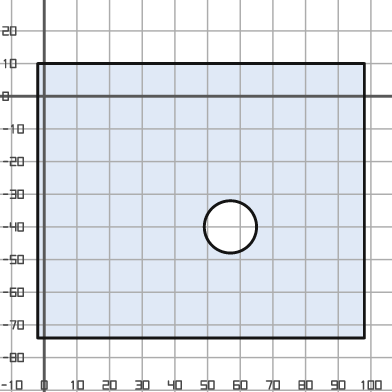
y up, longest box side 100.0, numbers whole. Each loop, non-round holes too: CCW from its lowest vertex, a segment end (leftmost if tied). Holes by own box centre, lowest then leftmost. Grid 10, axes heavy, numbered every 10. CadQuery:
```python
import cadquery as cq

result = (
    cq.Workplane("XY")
    .moveTo(-2.0, -74.0)
    .lineTo(98.0, -74.0)
    .lineTo(98.0, 10.0)
    .lineTo(-2.0, 10.0)
    .close()
    .moveTo(57.0, -40.0)
    .circle(8.0)
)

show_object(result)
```